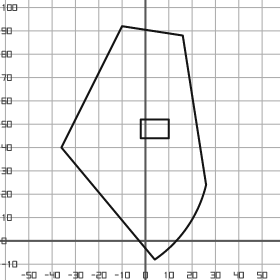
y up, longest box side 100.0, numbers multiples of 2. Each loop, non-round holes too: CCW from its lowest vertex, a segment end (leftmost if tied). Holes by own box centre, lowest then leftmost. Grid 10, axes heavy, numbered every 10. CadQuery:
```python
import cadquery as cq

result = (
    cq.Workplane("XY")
    .moveTo(4.0, -8.0)
    .threePointArc((18.0, 6.0), (26.0, 24.0))
    .lineTo(16.0, 88.0)
    .lineTo(-10.0, 92.0)
    .lineTo(-36.0, 40.0)
    .close()
    .moveTo(-2.0, 44.0)
    .lineTo(10.0, 44.0)
    .lineTo(10.0, 52.0)
    .lineTo(-2.0, 52.0)
    .close()
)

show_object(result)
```